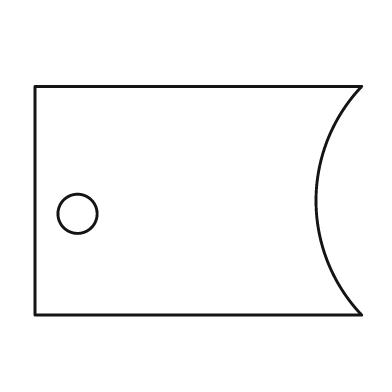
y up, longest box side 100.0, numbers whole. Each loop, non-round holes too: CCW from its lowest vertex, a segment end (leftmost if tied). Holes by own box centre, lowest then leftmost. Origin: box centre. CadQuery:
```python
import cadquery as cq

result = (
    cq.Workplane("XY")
    .moveTo(-50.0, -35.0)
    .lineTo(50.0, -35.0)
    .threePointArc((36.0, 0.0), (50.0, 35.0))
    .lineTo(-50.0, 35.0)
    .close()
    .moveTo(-37.0, -4.0)
    .circle(6.0)
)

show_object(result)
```